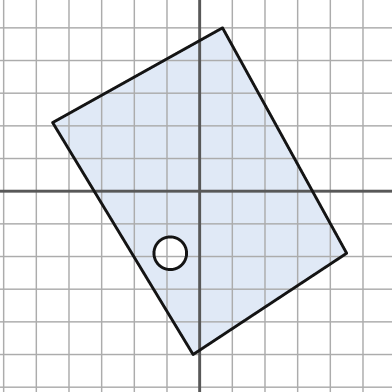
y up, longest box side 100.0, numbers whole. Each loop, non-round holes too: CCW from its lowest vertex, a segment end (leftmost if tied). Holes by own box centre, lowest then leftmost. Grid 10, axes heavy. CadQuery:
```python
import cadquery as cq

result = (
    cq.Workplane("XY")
    .moveTo(-2.0, -50.0)
    .lineTo(45.0, -19.0)
    .lineTo(7.0, 50.0)
    .lineTo(-45.0, 21.0)
    .close()
    .moveTo(-9.0, -19.0)
    .circle(5.0)
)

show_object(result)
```